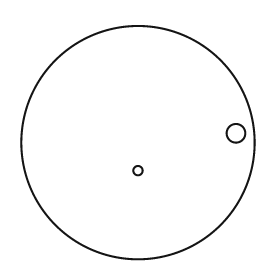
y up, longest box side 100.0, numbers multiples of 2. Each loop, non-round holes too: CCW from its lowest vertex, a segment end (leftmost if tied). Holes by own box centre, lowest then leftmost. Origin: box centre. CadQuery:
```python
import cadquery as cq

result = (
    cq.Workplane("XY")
    .moveTo(0.0, 0.0)
    .circle(50.0)
    .moveTo(0.0, -12.0)
    .circle(2.0)
    .moveTo(42.0, 4.0)
    .circle(4.0)
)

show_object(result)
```